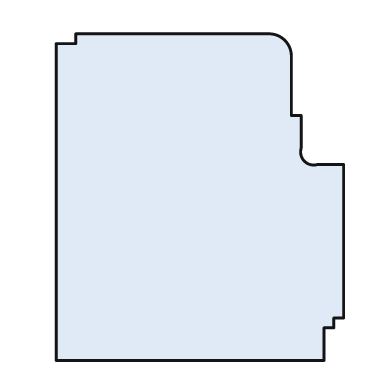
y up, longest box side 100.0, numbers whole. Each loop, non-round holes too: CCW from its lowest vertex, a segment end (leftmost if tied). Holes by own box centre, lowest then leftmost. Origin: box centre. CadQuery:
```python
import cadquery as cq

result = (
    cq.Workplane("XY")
    .moveTo(-44.0, -50.0)
    .lineTo(38.0, -50.0)
    .lineTo(38.0, -40.0)
    .lineTo(41.0, -40.0)
    .lineTo(41.0, -37.0)
    .lineTo(44.0, -37.0)
    .lineTo(44.0, 10.0)
    .lineTo(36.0, 10.0)
    .threePointArc((32.0, 11.0), (31.0, 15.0))
    .lineTo(31.0, 25.0)
    .lineTo(28.0, 25.0)
    .lineTo(28.0, 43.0)
    .threePointArc((26.0, 48.0), (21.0, 50.0))
    .lineTo(-38.0, 50.0)
    .lineTo(-38.0, 47.0)
    .lineTo(-44.0, 47.0)
    .close()
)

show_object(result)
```